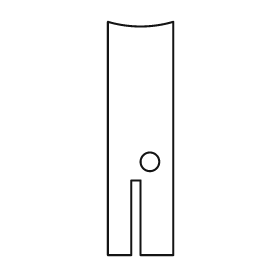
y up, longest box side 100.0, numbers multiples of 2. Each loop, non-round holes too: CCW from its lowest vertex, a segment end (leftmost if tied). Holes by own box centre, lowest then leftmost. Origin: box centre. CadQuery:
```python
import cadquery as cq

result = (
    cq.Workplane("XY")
    .moveTo(-14.0, -50.0)
    .lineTo(-4.0, -50.0)
    .lineTo(-4.0, -18.0)
    .lineTo(0.0, -18.0)
    .lineTo(0.0, -50.0)
    .lineTo(14.0, -50.0)
    .lineTo(14.0, 50.0)
    .threePointArc((0.0, 48.0), (-14.0, 50.0))
    .close()
    .moveTo(4.0, -10.0)
    .circle(4.0)
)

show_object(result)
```